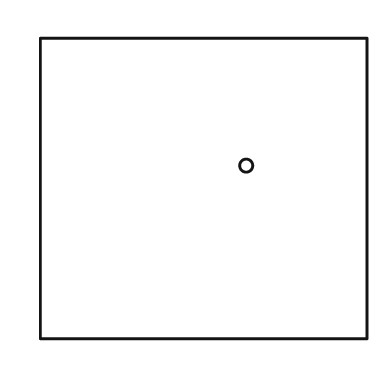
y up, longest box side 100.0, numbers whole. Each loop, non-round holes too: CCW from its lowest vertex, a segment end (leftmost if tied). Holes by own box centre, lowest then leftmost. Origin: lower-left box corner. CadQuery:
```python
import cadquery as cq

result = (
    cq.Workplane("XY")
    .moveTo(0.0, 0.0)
    .lineTo(100.0, 0.0)
    .lineTo(100.0, 92.0)
    .lineTo(0.0, 92.0)
    .close()
    .moveTo(63.0, 53.0)
    .circle(2.0)
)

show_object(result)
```